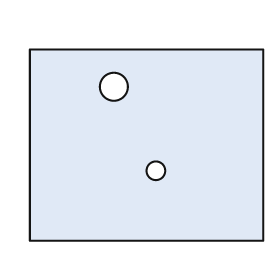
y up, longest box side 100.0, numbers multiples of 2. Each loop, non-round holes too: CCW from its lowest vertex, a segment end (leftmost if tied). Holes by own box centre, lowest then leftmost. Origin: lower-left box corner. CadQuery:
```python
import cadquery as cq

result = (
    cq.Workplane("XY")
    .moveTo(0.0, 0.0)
    .lineTo(100.0, 0.0)
    .lineTo(100.0, 82.0)
    .lineTo(0.0, 82.0)
    .close()
    .moveTo(54.0, 30.0)
    .circle(4.0)
    .moveTo(36.0, 66.0)
    .circle(6.0)
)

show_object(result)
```